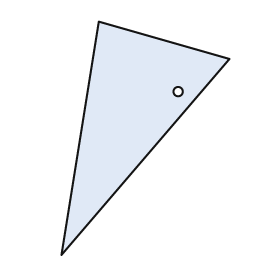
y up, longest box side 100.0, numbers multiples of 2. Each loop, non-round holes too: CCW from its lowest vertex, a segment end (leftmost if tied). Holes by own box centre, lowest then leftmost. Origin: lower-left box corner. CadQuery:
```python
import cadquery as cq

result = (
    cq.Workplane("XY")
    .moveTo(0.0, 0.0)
    .lineTo(72.0, 84.0)
    .lineTo(16.0, 100.0)
    .close()
    .moveTo(50.0, 70.0)
    .circle(2.0)
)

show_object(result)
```